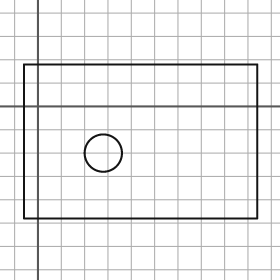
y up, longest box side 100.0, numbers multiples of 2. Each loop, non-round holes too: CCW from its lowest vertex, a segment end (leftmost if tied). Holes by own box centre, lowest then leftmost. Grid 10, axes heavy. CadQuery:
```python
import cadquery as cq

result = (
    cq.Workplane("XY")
    .moveTo(-6.0, -48.0)
    .lineTo(94.0, -48.0)
    .lineTo(94.0, 18.0)
    .lineTo(-6.0, 18.0)
    .close()
    .moveTo(28.0, -20.0)
    .circle(8.0)
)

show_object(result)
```